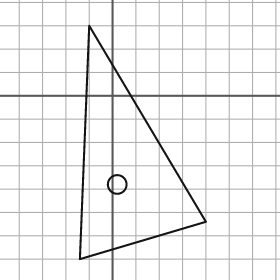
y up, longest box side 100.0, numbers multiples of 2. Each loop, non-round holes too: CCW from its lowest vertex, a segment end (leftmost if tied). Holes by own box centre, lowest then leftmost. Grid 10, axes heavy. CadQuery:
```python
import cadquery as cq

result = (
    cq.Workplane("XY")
    .moveTo(-14.0, -70.0)
    .lineTo(40.0, -54.0)
    .lineTo(-10.0, 30.0)
    .close()
    .moveTo(2.0, -38.0)
    .circle(4.0)
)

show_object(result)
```